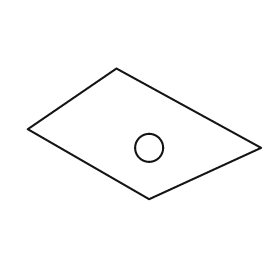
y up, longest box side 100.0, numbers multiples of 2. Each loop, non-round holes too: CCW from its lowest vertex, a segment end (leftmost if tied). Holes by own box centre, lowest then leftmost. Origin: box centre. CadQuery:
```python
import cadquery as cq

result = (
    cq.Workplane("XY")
    .moveTo(2.0, -28.0)
    .lineTo(50.0, -6.0)
    .lineTo(-12.0, 28.0)
    .lineTo(-50.0, 2.0)
    .close()
    .moveTo(2.0, -6.0)
    .circle(6.0)
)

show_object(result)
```